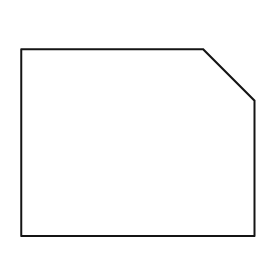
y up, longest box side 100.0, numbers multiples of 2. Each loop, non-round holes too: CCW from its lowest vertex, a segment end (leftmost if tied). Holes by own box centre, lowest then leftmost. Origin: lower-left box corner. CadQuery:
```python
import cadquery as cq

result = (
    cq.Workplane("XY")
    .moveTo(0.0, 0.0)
    .lineTo(100.0, 0.0)
    .lineTo(100.0, 58.0)
    .lineTo(78.0, 80.0)
    .lineTo(0.0, 80.0)
    .close()
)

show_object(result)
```